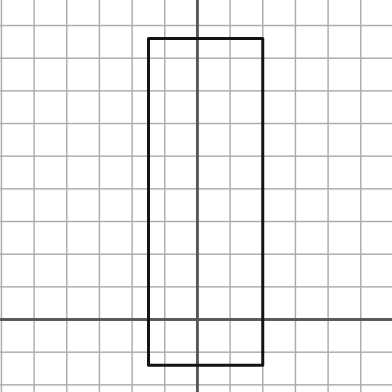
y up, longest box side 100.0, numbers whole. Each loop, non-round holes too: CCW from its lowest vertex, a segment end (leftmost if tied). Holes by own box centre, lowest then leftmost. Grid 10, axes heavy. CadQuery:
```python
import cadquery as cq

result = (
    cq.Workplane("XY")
    .moveTo(-15.0, -14.0)
    .lineTo(20.0, -14.0)
    .lineTo(20.0, 86.0)
    .lineTo(-15.0, 86.0)
    .close()
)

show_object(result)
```